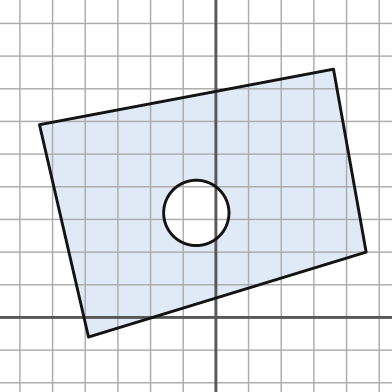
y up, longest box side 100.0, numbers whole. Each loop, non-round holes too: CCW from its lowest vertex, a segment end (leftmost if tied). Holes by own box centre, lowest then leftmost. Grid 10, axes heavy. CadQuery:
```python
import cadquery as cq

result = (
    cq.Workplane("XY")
    .moveTo(-39.0, -6.0)
    .lineTo(46.0, 20.0)
    .lineTo(36.0, 76.0)
    .lineTo(-54.0, 59.0)
    .close()
    .moveTo(-6.0, 32.0)
    .circle(10.0)
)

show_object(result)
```